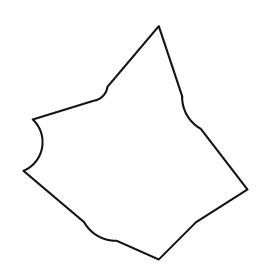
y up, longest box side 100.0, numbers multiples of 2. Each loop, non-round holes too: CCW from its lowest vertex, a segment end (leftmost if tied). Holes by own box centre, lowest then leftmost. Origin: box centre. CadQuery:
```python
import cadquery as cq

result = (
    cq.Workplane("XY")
    .moveTo(10.0, -50.0)
    .lineTo(26.0, -34.0)
    .lineTo(48.0, -20.0)
    .lineTo(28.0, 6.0)
    .threePointArc((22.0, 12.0), (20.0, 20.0))
    .lineTo(10.0, 50.0)
    .lineTo(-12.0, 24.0)
    .threePointArc((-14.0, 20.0), (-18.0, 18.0))
    .lineTo(-44.0, 10.0)
    .threePointArc((-40.0, -2.0), (-48.0, -12.0))
    .lineTo(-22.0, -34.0)
    .threePointArc((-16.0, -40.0), (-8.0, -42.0))
    .close()
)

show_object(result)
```